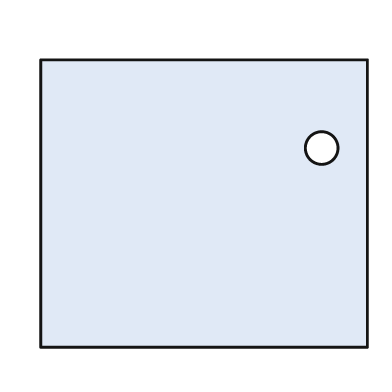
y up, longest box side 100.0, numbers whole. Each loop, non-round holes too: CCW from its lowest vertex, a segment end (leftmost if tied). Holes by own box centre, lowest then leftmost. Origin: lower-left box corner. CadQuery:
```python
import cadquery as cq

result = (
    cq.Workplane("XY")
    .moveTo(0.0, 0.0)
    .lineTo(100.0, 0.0)
    .lineTo(100.0, 88.0)
    .lineTo(0.0, 88.0)
    .close()
    .moveTo(86.0, 61.0)
    .circle(5.0)
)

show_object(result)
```